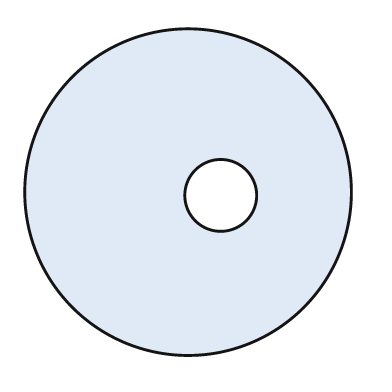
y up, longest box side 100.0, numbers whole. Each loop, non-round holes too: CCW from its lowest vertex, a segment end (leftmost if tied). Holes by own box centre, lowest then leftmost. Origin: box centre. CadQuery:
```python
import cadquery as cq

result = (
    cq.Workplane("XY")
    .moveTo(0.0, 0.0)
    .circle(50.0)
    .moveTo(10.0, -1.0)
    .circle(11.0)
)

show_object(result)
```